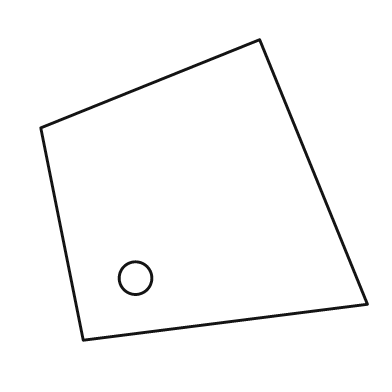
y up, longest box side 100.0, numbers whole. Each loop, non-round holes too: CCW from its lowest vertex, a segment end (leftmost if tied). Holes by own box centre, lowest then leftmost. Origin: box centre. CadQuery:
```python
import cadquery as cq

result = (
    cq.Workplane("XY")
    .moveTo(-37.0, -46.0)
    .lineTo(50.0, -35.0)
    .lineTo(17.0, 46.0)
    .lineTo(-50.0, 19.0)
    .close()
    .moveTo(-21.0, -27.0)
    .circle(5.0)
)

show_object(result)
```